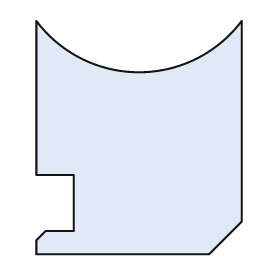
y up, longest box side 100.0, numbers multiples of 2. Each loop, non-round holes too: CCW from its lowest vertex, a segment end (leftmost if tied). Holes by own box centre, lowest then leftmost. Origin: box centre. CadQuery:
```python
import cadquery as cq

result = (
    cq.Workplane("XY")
    .moveTo(-44.0, -50.0)
    .lineTo(30.0, -50.0)
    .lineTo(44.0, -36.0)
    .lineTo(44.0, 50.0)
    .threePointArc((0.0, 28.0), (-44.0, 50.0))
    .lineTo(-44.0, -16.0)
    .lineTo(-28.0, -16.0)
    .lineTo(-28.0, -40.0)
    .lineTo(-40.0, -40.0)
    .lineTo(-44.0, -44.0)
    .close()
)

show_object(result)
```